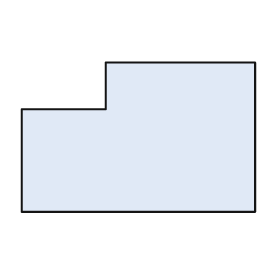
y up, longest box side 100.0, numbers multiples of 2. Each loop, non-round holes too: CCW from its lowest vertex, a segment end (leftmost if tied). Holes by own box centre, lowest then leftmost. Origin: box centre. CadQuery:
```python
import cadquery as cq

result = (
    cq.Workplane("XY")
    .moveTo(-50.0, -32.0)
    .lineTo(50.0, -32.0)
    .lineTo(50.0, 32.0)
    .lineTo(-14.0, 32.0)
    .lineTo(-14.0, 12.0)
    .lineTo(-50.0, 12.0)
    .close()
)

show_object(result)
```